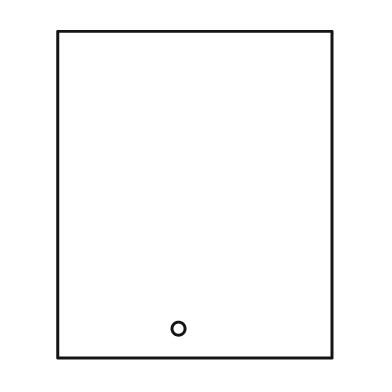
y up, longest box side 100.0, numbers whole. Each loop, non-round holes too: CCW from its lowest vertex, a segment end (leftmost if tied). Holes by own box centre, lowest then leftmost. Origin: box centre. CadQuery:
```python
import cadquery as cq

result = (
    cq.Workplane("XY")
    .moveTo(-42.0, -50.0)
    .lineTo(42.0, -50.0)
    .lineTo(42.0, 50.0)
    .lineTo(-42.0, 50.0)
    .close()
    .moveTo(-5.0, -41.0)
    .circle(2.0)
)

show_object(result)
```